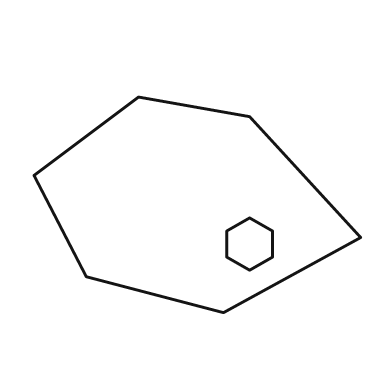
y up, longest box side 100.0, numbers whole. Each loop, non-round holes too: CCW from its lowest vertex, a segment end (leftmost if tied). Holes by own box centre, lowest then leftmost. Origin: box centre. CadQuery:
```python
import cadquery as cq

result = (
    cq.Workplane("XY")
    .moveTo(8.0, -33.0)
    .lineTo(50.0, -10.0)
    .lineTo(16.0, 27.0)
    .lineTo(-18.0, 33.0)
    .lineTo(-50.0, 9.0)
    .lineTo(-34.0, -22.0)
    .close()
    .moveTo(16.0, -20.0)
    .lineTo(23.0, -16.0)
    .lineTo(23.0, -8.0)
    .lineTo(16.0, -4.0)
    .lineTo(9.0, -8.0)
    .lineTo(9.0, -16.0)
    .close()
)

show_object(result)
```